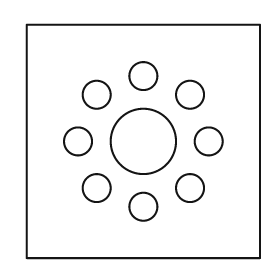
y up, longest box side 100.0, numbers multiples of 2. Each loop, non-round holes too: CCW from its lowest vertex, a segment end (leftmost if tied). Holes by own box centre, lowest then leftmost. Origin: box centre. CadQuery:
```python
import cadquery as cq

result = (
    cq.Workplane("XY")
    .moveTo(-50.0, -50.0)
    .lineTo(50.0, -50.0)
    .lineTo(50.0, 50.0)
    .lineTo(-50.0, 50.0)
    .close()
    .moveTo(0.0, -28.0)
    .circle(6.0)
    .moveTo(-20.0, -20.0)
    .circle(6.0)
    .moveTo(20.0, -20.0)
    .circle(6.0)
    .moveTo(-28.0, 0.0)
    .circle(6.0)
    .moveTo(0.0, 0.0)
    .circle(14.0)
    .moveTo(28.0, 0.0)
    .circle(6.0)
    .moveTo(-20.0, 20.0)
    .circle(6.0)
    .moveTo(20.0, 20.0)
    .circle(6.0)
    .moveTo(0.0, 28.0)
    .circle(6.0)
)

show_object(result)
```